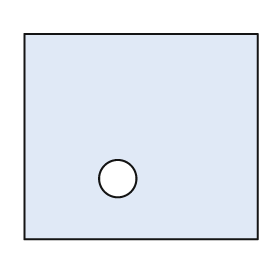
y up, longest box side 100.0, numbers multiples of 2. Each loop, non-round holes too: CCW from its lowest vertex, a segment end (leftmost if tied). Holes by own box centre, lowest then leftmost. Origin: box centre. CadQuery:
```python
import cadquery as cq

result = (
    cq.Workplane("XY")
    .moveTo(-50.0, -44.0)
    .lineTo(50.0, -44.0)
    .lineTo(50.0, 44.0)
    .lineTo(-50.0, 44.0)
    .close()
    .moveTo(-10.0, -18.0)
    .circle(8.0)
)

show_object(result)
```